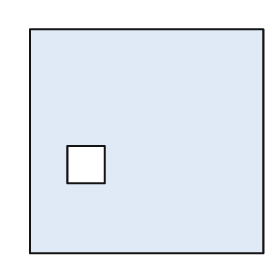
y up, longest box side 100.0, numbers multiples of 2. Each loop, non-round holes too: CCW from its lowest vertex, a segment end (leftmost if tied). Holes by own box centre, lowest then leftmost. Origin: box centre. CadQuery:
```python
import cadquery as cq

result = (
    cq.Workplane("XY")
    .moveTo(-50.0, -48.0)
    .lineTo(50.0, -48.0)
    .lineTo(50.0, 48.0)
    .lineTo(-50.0, 48.0)
    .close()
    .moveTo(-34.0, -18.0)
    .lineTo(-18.0, -18.0)
    .lineTo(-18.0, -2.0)
    .lineTo(-34.0, -2.0)
    .close()
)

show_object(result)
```